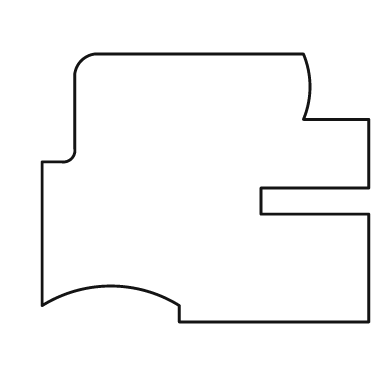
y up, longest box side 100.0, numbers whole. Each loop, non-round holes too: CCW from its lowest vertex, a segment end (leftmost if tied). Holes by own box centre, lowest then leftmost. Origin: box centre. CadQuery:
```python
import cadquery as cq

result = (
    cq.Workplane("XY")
    .moveTo(-8.0, -41.0)
    .lineTo(50.0, -41.0)
    .lineTo(50.0, -8.0)
    .lineTo(17.0, -8.0)
    .lineTo(17.0, 0.0)
    .lineTo(50.0, 0.0)
    .lineTo(50.0, 21.0)
    .lineTo(30.0, 21.0)
    .threePointArc((32.0, 31.0), (30.0, 41.0))
    .lineTo(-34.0, 41.0)
    .threePointArc((-38.0, 39.0), (-40.0, 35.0))
    .lineTo(-40.0, 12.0)
    .threePointArc((-41.0, 9.0), (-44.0, 8.0))
    .lineTo(-50.0, 8.0)
    .lineTo(-50.0, -36.0)
    .threePointArc((-29.0, -30.0), (-8.0, -36.0))
    .close()
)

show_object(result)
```